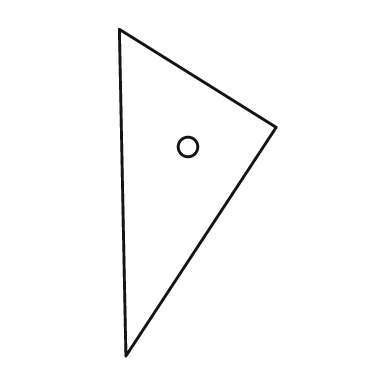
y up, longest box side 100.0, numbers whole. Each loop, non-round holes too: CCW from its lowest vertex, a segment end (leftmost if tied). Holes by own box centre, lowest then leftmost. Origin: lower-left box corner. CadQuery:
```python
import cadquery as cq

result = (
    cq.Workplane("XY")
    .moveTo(2.0, 0.0)
    .lineTo(48.0, 70.0)
    .lineTo(0.0, 100.0)
    .close()
    .moveTo(21.0, 64.0)
    .circle(3.0)
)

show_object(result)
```